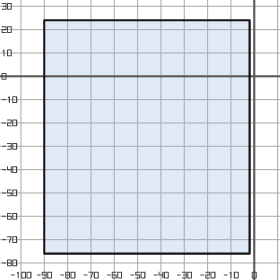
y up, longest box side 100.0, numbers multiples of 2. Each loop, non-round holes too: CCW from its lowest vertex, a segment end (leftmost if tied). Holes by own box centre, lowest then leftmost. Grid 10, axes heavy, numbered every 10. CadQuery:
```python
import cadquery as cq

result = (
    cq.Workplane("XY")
    .moveTo(-90.0, -76.0)
    .lineTo(-2.0, -76.0)
    .lineTo(-2.0, 24.0)
    .lineTo(-90.0, 24.0)
    .close()
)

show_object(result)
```